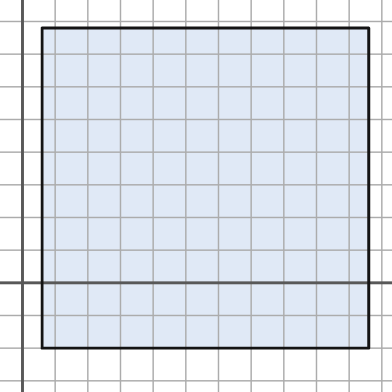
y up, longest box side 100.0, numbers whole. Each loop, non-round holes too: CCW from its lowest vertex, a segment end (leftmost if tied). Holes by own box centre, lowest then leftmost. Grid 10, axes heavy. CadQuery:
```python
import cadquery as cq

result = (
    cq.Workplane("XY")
    .moveTo(6.0, -20.0)
    .lineTo(106.0, -20.0)
    .lineTo(106.0, 78.0)
    .lineTo(6.0, 78.0)
    .close()
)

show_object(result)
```